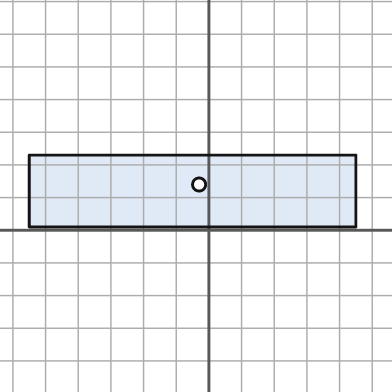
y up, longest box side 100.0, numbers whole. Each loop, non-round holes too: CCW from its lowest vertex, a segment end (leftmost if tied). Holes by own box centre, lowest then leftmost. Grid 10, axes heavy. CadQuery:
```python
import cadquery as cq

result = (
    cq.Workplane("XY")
    .moveTo(-55.0, 1.0)
    .lineTo(45.0, 1.0)
    .lineTo(45.0, 23.0)
    .lineTo(-55.0, 23.0)
    .close()
    .moveTo(-3.0, 14.0)
    .circle(2.0)
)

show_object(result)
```